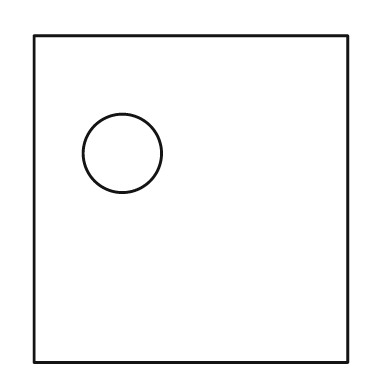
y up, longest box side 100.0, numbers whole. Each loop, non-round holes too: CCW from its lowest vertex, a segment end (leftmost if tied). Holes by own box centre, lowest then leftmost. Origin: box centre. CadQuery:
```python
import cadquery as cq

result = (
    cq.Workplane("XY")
    .moveTo(-48.0, -50.0)
    .lineTo(48.0, -50.0)
    .lineTo(48.0, 50.0)
    .lineTo(-48.0, 50.0)
    .close()
    .moveTo(-21.0, 14.0)
    .circle(12.0)
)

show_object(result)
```